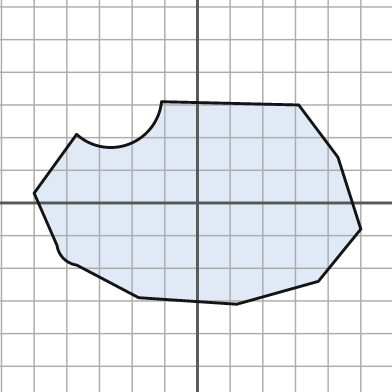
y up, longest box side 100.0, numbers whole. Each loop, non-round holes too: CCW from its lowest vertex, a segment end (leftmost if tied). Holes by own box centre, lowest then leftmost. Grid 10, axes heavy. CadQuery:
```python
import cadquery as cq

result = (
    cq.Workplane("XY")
    .moveTo(12.0, -31.0)
    .lineTo(37.0, -24.0)
    .lineTo(50.0, -8.0)
    .lineTo(43.0, 14.0)
    .lineTo(31.0, 30.0)
    .lineTo(-11.0, 31.0)
    .threePointArc((-21.0, 18.0), (-37.0, 21.0))
    .lineTo(-50.0, 3.0)
    .lineTo(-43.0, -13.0)
    .threePointArc((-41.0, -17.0), (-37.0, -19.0))
    .lineTo(-18.0, -29.0)
    .close()
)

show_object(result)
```